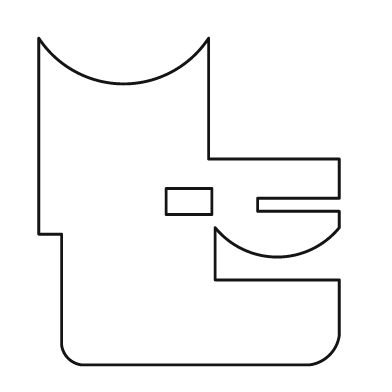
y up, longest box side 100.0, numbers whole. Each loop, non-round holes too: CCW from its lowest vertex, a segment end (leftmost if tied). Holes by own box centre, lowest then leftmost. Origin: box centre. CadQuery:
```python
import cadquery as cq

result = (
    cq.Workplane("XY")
    .moveTo(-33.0, -50.0)
    .lineTo(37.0, -50.0)
    .threePointArc((43.0, -47.0), (46.0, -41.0))
    .lineTo(46.0, -24.0)
    .lineTo(8.0, -24.0)
    .lineTo(8.0, -8.0)
    .threePointArc((27.0, -17.0), (46.0, -8.0))
    .lineTo(46.0, -3.0)
    .lineTo(21.0, -3.0)
    .lineTo(21.0, 1.0)
    .lineTo(46.0, 1.0)
    .lineTo(46.0, 13.0)
    .lineTo(6.0, 13.0)
    .lineTo(6.0, 50.0)
    .threePointArc((-20.0, 36.0), (-46.0, 50.0))
    .lineTo(-46.0, -10.0)
    .lineTo(-39.0, -10.0)
    .lineTo(-39.0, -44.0)
    .threePointArc((-37.0, -48.0), (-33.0, -50.0))
    .close()
    .moveTo(-7.0, -4.0)
    .lineTo(7.0, -4.0)
    .lineTo(7.0, 4.0)
    .lineTo(-7.0, 4.0)
    .close()
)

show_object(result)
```